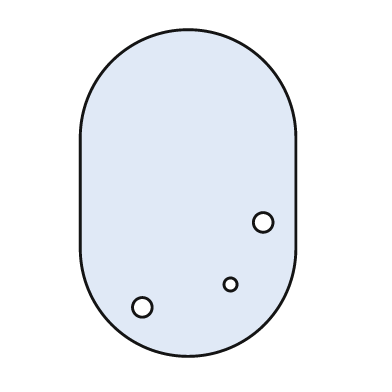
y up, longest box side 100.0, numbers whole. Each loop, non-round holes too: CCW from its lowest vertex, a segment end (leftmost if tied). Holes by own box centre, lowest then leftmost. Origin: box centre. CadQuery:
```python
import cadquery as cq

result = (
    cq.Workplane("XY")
    .moveTo(-33.0, -17.0)
    .threePointArc((0.0, -50.0), (33.0, -17.0))
    .lineTo(33.0, 17.0)
    .threePointArc((0.0, 50.0), (-33.0, 17.0))
    .close()
    .moveTo(-14.0, -35.0)
    .circle(3.0)
    .moveTo(13.0, -28.0)
    .circle(2.0)
    .moveTo(23.0, -9.0)
    .circle(3.0)
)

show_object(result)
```